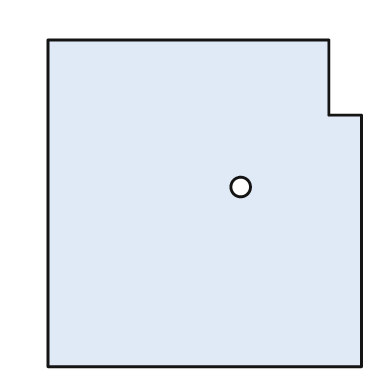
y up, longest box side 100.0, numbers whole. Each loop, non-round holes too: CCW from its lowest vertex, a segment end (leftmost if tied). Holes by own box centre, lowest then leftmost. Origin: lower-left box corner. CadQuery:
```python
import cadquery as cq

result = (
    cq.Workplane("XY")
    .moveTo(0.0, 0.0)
    .lineTo(96.0, 0.0)
    .lineTo(96.0, 77.0)
    .lineTo(86.0, 77.0)
    .lineTo(86.0, 100.0)
    .lineTo(0.0, 100.0)
    .close()
    .moveTo(59.0, 55.0)
    .circle(3.0)
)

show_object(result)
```